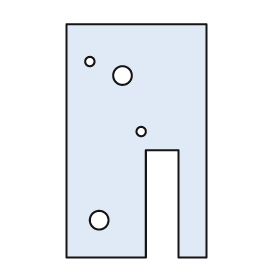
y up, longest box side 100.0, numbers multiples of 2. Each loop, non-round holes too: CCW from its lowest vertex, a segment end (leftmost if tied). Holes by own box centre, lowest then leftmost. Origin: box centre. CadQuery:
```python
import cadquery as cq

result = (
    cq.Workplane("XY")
    .moveTo(-30.0, -50.0)
    .lineTo(4.0, -50.0)
    .lineTo(4.0, -4.0)
    .lineTo(18.0, -4.0)
    .lineTo(18.0, -50.0)
    .lineTo(30.0, -50.0)
    .lineTo(30.0, 50.0)
    .lineTo(-30.0, 50.0)
    .close()
    .moveTo(-16.0, -34.0)
    .circle(4.0)
    .moveTo(2.0, 4.0)
    .circle(2.0)
    .moveTo(-6.0, 28.0)
    .circle(4.0)
    .moveTo(-20.0, 34.0)
    .circle(2.0)
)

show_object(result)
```